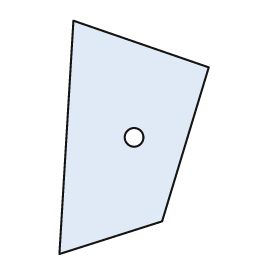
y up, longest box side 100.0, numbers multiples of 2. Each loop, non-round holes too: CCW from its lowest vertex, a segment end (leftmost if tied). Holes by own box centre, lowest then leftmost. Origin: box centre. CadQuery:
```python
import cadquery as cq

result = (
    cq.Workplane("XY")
    .moveTo(-32.0, -50.0)
    .lineTo(12.0, -36.0)
    .lineTo(32.0, 30.0)
    .lineTo(-26.0, 50.0)
    .close()
    .moveTo(0.0, 0.0)
    .circle(4.0)
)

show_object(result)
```